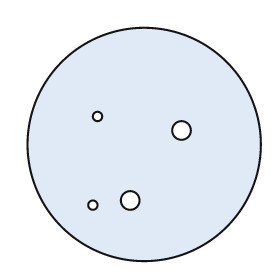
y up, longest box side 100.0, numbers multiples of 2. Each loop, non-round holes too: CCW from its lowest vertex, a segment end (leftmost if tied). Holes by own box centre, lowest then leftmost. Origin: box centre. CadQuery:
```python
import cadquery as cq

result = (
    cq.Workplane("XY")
    .moveTo(0.0, 0.0)
    .circle(50.0)
    .moveTo(-22.0, -26.0)
    .circle(2.0)
    .moveTo(-6.0, -24.0)
    .circle(4.0)
    .moveTo(16.0, 6.0)
    .circle(4.0)
    .moveTo(-20.0, 12.0)
    .circle(2.0)
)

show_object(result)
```